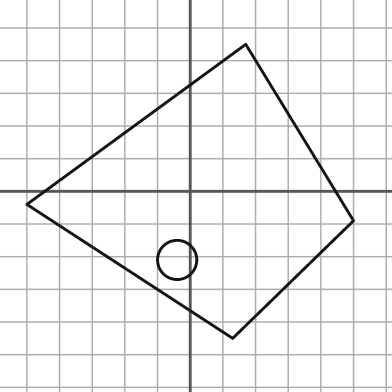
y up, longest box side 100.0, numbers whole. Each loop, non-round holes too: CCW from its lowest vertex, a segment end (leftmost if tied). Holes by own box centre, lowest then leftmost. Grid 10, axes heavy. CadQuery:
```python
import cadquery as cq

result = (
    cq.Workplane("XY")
    .moveTo(13.0, -45.0)
    .lineTo(50.0, -9.0)
    .lineTo(17.0, 45.0)
    .lineTo(-50.0, -4.0)
    .close()
    .moveTo(-4.0, -21.0)
    .circle(6.0)
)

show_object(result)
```